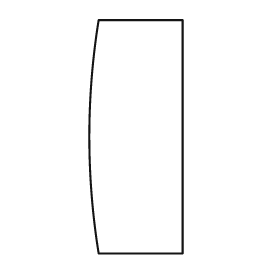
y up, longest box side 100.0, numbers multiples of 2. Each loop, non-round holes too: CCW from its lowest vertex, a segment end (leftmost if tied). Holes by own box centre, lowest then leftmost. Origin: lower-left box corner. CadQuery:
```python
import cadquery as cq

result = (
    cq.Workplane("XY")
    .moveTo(4.0, 0.0)
    .lineTo(40.0, 0.0)
    .lineTo(40.0, 100.0)
    .lineTo(4.0, 100.0)
    .threePointArc((0.0, 50.0), (4.0, 0.0))
    .close()
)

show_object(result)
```